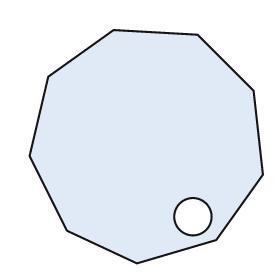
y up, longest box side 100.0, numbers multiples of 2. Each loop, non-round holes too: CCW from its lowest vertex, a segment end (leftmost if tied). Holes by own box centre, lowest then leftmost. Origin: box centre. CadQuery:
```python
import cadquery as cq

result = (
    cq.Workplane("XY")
    .moveTo(-4.0, -50.0)
    .lineTo(30.0, -40.0)
    .lineTo(50.0, -12.0)
    .lineTo(46.0, 24.0)
    .lineTo(22.0, 48.0)
    .lineTo(-14.0, 50.0)
    .lineTo(-42.0, 30.0)
    .lineTo(-50.0, -4.0)
    .lineTo(-34.0, -36.0)
    .close()
    .moveTo(20.0, -30.0)
    .circle(8.0)
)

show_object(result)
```